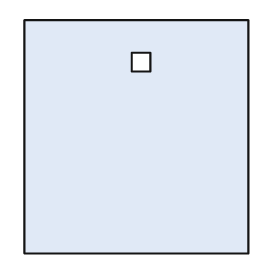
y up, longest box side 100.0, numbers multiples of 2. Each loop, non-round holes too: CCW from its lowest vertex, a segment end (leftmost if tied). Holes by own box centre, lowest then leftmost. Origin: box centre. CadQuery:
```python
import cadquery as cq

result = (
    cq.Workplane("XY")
    .moveTo(-48.0, -50.0)
    .lineTo(48.0, -50.0)
    .lineTo(48.0, 50.0)
    .lineTo(-48.0, 50.0)
    .close()
    .moveTo(-2.0, 28.0)
    .lineTo(6.0, 28.0)
    .lineTo(6.0, 36.0)
    .lineTo(-2.0, 36.0)
    .close()
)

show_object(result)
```